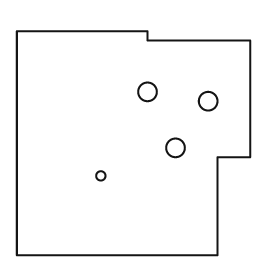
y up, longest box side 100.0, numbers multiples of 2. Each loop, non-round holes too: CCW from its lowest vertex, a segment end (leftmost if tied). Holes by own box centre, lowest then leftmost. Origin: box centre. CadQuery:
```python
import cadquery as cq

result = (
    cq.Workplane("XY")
    .moveTo(-50.0, -48.0)
    .lineTo(36.0, -48.0)
    .lineTo(36.0, -6.0)
    .lineTo(50.0, -6.0)
    .lineTo(50.0, 44.0)
    .lineTo(6.0, 44.0)
    .lineTo(6.0, 48.0)
    .lineTo(-50.0, 48.0)
    .close()
    .moveTo(-14.0, -14.0)
    .circle(2.0)
    .moveTo(18.0, -2.0)
    .circle(4.0)
    .moveTo(32.0, 18.0)
    .circle(4.0)
    .moveTo(6.0, 22.0)
    .circle(4.0)
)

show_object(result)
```